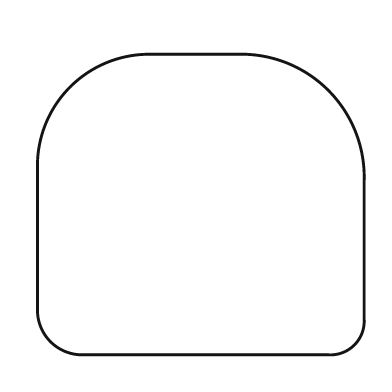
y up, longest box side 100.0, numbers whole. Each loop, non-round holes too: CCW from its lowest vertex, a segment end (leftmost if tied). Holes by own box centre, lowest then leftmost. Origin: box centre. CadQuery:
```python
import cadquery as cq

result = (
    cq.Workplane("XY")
    .moveTo(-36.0, -46.0)
    .lineTo(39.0, -46.0)
    .threePointArc((47.0, -43.0), (50.0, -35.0))
    .lineTo(50.0, 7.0)
    .threePointArc((39.0, 35.0), (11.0, 46.0))
    .lineTo(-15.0, 46.0)
    .threePointArc((-40.0, 36.0), (-50.0, 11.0))
    .lineTo(-50.0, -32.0)
    .threePointArc((-46.0, -42.0), (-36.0, -46.0))
    .close()
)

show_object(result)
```